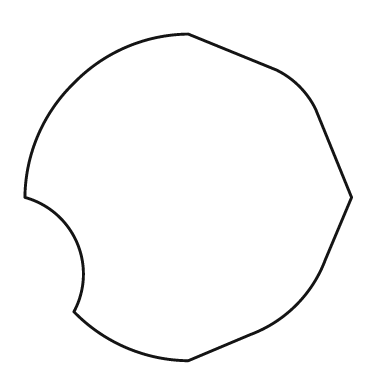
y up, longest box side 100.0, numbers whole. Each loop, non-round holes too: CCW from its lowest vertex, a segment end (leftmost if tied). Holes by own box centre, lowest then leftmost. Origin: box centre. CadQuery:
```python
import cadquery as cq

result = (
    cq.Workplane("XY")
    .moveTo(0.0, -50.0)
    .lineTo(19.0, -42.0)
    .threePointArc((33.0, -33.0), (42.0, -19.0))
    .lineTo(50.0, 0.0)
    .lineTo(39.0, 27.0)
    .threePointArc((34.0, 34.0), (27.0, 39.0))
    .lineTo(0.0, 50.0)
    .threePointArc((-19.0, 46.0), (-35.0, 35.0))
    .threePointArc((-46.0, 19.0), (-50.0, 0.0))
    .threePointArc((-34.0, -14.0), (-35.0, -35.0))
    .threePointArc((-19.0, -46.0), (0.0, -50.0))
    .close()
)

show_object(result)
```